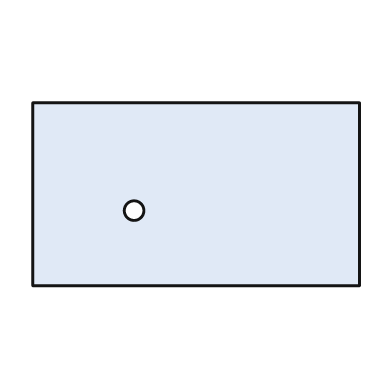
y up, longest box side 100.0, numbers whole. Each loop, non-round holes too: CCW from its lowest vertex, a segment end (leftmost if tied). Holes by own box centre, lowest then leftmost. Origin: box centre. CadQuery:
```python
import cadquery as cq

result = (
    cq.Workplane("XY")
    .moveTo(-50.0, -28.0)
    .lineTo(50.0, -28.0)
    .lineTo(50.0, 28.0)
    .lineTo(-50.0, 28.0)
    .close()
    .moveTo(-19.0, -5.0)
    .circle(3.0)
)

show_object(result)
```